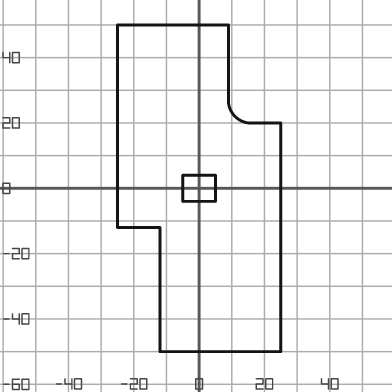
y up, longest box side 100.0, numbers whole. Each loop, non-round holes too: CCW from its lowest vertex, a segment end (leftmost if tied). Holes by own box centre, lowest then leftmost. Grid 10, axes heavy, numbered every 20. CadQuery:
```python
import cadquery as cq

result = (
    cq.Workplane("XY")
    .moveTo(-12.0, -50.0)
    .lineTo(25.0, -50.0)
    .lineTo(25.0, 20.0)
    .lineTo(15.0, 20.0)
    .threePointArc((11.0, 22.0), (9.0, 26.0))
    .lineTo(9.0, 50.0)
    .lineTo(-25.0, 50.0)
    .lineTo(-25.0, -12.0)
    .lineTo(-12.0, -12.0)
    .close()
    .moveTo(-5.0, -4.0)
    .lineTo(5.0, -4.0)
    .lineTo(5.0, 4.0)
    .lineTo(-5.0, 4.0)
    .close()
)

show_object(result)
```